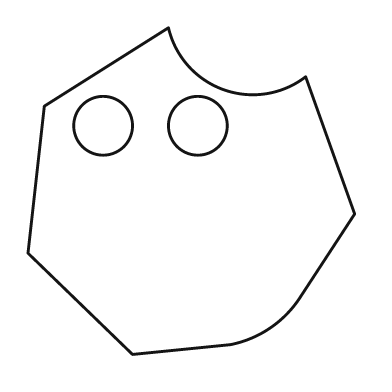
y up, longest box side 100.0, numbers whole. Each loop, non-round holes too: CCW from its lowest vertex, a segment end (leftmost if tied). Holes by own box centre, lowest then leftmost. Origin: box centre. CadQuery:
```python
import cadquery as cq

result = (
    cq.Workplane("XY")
    .moveTo(-18.0, -50.0)
    .lineTo(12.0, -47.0)
    .threePointArc((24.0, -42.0), (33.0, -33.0))
    .lineTo(50.0, -7.0)
    .lineTo(35.0, 35.0)
    .threePointArc((10.0, 31.0), (-7.0, 50.0))
    .lineTo(-45.0, 26.0)
    .lineTo(-50.0, -19.0)
    .close()
    .moveTo(-27.0, 20.0)
    .circle(9.0)
    .moveTo(2.0, 20.0)
    .circle(9.0)
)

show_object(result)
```